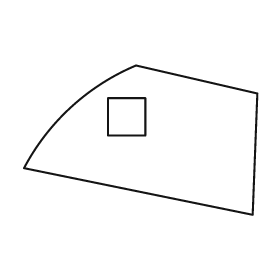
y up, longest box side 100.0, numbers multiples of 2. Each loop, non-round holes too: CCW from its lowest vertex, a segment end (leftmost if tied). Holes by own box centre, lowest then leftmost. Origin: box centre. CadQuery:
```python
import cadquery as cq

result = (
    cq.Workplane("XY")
    .moveTo(48.0, -32.0)
    .lineTo(50.0, 20.0)
    .lineTo(-2.0, 32.0)
    .threePointArc((-30.0, 14.0), (-50.0, -12.0))
    .close()
    .moveTo(-14.0, 2.0)
    .lineTo(2.0, 2.0)
    .lineTo(2.0, 18.0)
    .lineTo(-14.0, 18.0)
    .close()
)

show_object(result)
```